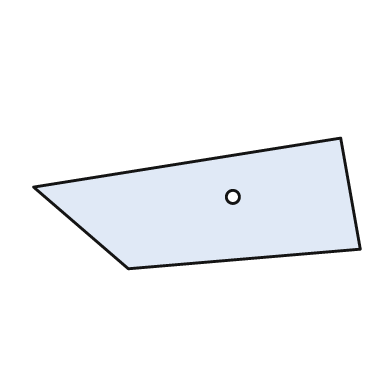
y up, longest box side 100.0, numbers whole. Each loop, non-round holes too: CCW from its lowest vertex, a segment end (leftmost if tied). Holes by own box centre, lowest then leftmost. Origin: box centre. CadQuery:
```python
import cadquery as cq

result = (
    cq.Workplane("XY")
    .moveTo(-21.0, -20.0)
    .lineTo(50.0, -14.0)
    .lineTo(44.0, 20.0)
    .lineTo(-50.0, 5.0)
    .close()
    .moveTo(11.0, 2.0)
    .circle(2.0)
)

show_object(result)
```